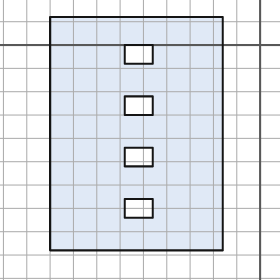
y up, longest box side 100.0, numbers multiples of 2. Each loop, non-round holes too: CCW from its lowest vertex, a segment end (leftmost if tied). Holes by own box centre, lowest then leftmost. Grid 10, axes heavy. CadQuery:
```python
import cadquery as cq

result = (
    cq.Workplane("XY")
    .moveTo(-90.0, -88.0)
    .lineTo(-16.0, -88.0)
    .lineTo(-16.0, 12.0)
    .lineTo(-90.0, 12.0)
    .close()
    .moveTo(-58.0, -74.0)
    .lineTo(-46.0, -74.0)
    .lineTo(-46.0, -66.0)
    .lineTo(-58.0, -66.0)
    .close()
    .moveTo(-58.0, -52.0)
    .lineTo(-46.0, -52.0)
    .lineTo(-46.0, -44.0)
    .lineTo(-58.0, -44.0)
    .close()
    .moveTo(-58.0, -30.0)
    .lineTo(-46.0, -30.0)
    .lineTo(-46.0, -22.0)
    .lineTo(-58.0, -22.0)
    .close()
    .moveTo(-58.0, -8.0)
    .lineTo(-46.0, -8.0)
    .lineTo(-46.0, 0.0)
    .lineTo(-58.0, 0.0)
    .close()
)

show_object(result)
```